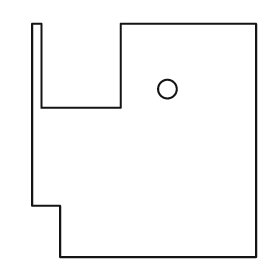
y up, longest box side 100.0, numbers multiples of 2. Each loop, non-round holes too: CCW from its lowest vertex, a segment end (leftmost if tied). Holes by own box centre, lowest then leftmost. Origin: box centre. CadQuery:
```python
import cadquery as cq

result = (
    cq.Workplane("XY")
    .moveTo(-36.0, -50.0)
    .lineTo(48.0, -50.0)
    .lineTo(48.0, 50.0)
    .lineTo(-10.0, 50.0)
    .lineTo(-10.0, 14.0)
    .lineTo(-44.0, 14.0)
    .lineTo(-44.0, 50.0)
    .lineTo(-48.0, 50.0)
    .lineTo(-48.0, -28.0)
    .lineTo(-36.0, -28.0)
    .close()
    .moveTo(10.0, 22.0)
    .circle(4.0)
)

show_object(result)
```